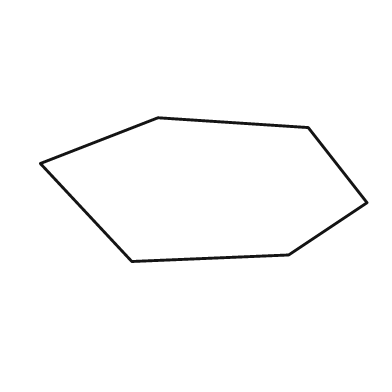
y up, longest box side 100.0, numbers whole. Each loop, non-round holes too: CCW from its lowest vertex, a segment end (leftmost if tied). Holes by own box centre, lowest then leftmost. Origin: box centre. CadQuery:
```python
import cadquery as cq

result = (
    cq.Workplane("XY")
    .moveTo(-22.0, -22.0)
    .lineTo(26.0, -20.0)
    .lineTo(50.0, -4.0)
    .lineTo(32.0, 19.0)
    .lineTo(-14.0, 22.0)
    .lineTo(-50.0, 8.0)
    .close()
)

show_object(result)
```